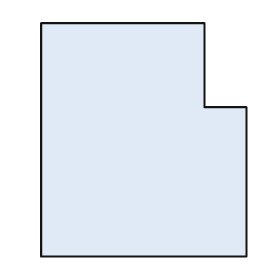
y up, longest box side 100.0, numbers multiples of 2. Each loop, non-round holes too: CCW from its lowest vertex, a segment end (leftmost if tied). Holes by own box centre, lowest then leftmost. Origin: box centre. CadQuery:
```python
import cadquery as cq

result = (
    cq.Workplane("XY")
    .moveTo(-44.0, -50.0)
    .lineTo(44.0, -50.0)
    .lineTo(44.0, 14.0)
    .lineTo(26.0, 14.0)
    .lineTo(26.0, 50.0)
    .lineTo(-44.0, 50.0)
    .close()
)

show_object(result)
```